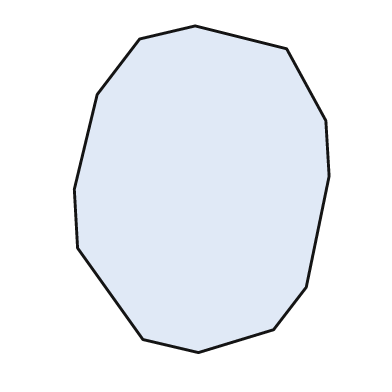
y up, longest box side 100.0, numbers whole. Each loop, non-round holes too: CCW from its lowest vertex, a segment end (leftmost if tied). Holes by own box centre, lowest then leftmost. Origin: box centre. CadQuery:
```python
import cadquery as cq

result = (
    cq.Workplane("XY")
    .moveTo(-1.0, -50.0)
    .lineTo(22.0, -43.0)
    .lineTo(32.0, -30.0)
    .lineTo(39.0, 4.0)
    .lineTo(38.0, 21.0)
    .lineTo(26.0, 43.0)
    .lineTo(-2.0, 50.0)
    .lineTo(-19.0, 46.0)
    .lineTo(-32.0, 29.0)
    .lineTo(-39.0, 0.0)
    .lineTo(-38.0, -18.0)
    .lineTo(-18.0, -46.0)
    .close()
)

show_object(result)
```